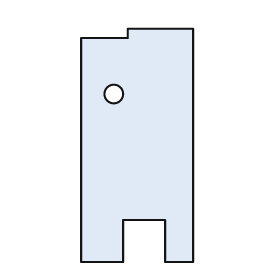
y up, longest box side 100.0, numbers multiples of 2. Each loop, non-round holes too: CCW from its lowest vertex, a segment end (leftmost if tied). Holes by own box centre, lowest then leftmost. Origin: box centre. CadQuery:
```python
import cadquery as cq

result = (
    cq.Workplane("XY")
    .moveTo(-24.0, -50.0)
    .lineTo(-6.0, -50.0)
    .lineTo(-6.0, -32.0)
    .lineTo(12.0, -32.0)
    .lineTo(12.0, -50.0)
    .lineTo(24.0, -50.0)
    .lineTo(24.0, 50.0)
    .lineTo(-4.0, 50.0)
    .lineTo(-4.0, 46.0)
    .lineTo(-24.0, 46.0)
    .close()
    .moveTo(-10.0, 22.0)
    .circle(4.0)
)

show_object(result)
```